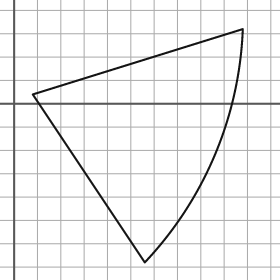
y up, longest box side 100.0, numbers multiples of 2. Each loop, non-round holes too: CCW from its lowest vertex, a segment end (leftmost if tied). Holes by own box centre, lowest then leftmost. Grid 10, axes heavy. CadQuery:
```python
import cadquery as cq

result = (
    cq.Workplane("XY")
    .moveTo(56.0, -68.0)
    .threePointArc((86.0, -22.0), (98.0, 32.0))
    .lineTo(8.0, 4.0)
    .close()
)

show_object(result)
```